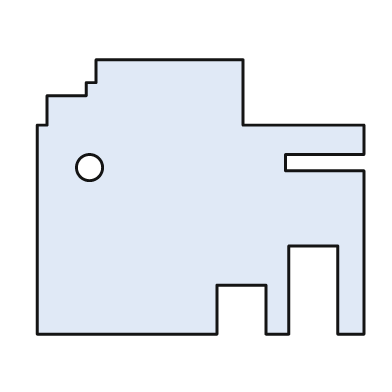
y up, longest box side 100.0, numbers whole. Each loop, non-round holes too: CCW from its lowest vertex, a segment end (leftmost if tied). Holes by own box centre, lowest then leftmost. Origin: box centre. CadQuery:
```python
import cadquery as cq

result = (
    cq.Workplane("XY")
    .moveTo(-50.0, -42.0)
    .lineTo(5.0, -42.0)
    .lineTo(5.0, -27.0)
    .lineTo(20.0, -27.0)
    .lineTo(20.0, -42.0)
    .lineTo(27.0, -42.0)
    .lineTo(27.0, -15.0)
    .lineTo(42.0, -15.0)
    .lineTo(42.0, -42.0)
    .lineTo(50.0, -42.0)
    .lineTo(50.0, 8.0)
    .lineTo(26.0, 8.0)
    .lineTo(26.0, 13.0)
    .lineTo(50.0, 13.0)
    .lineTo(50.0, 22.0)
    .lineTo(13.0, 22.0)
    .lineTo(13.0, 42.0)
    .lineTo(-32.0, 42.0)
    .lineTo(-32.0, 35.0)
    .lineTo(-35.0, 35.0)
    .lineTo(-35.0, 31.0)
    .lineTo(-47.0, 31.0)
    .lineTo(-47.0, 22.0)
    .lineTo(-50.0, 22.0)
    .close()
    .moveTo(-34.0, 9.0)
    .circle(4.0)
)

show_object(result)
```